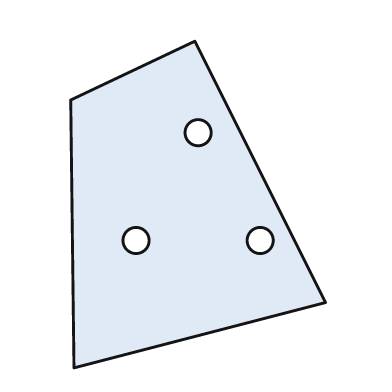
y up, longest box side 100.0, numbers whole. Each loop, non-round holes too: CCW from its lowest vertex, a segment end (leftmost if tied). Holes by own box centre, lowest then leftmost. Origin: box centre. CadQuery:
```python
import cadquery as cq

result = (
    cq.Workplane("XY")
    .moveTo(-38.0, -50.0)
    .lineTo(39.0, -30.0)
    .lineTo(-1.0, 50.0)
    .lineTo(-39.0, 32.0)
    .close()
    .moveTo(-19.0, -11.0)
    .circle(4.0)
    .moveTo(19.0, -11.0)
    .circle(4.0)
    .moveTo(0.0, 22.0)
    .circle(4.0)
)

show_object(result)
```